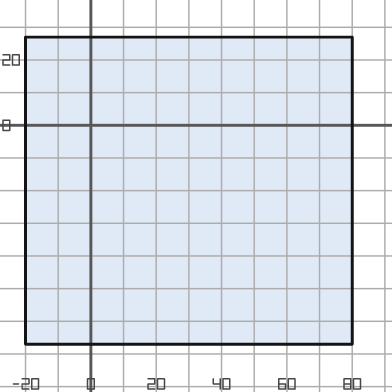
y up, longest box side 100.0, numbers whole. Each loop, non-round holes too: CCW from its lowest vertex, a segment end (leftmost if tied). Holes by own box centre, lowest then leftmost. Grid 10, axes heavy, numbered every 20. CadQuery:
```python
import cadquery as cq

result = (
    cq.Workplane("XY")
    .moveTo(-20.0, -67.0)
    .lineTo(80.0, -67.0)
    .lineTo(80.0, 27.0)
    .lineTo(-20.0, 27.0)
    .close()
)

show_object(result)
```